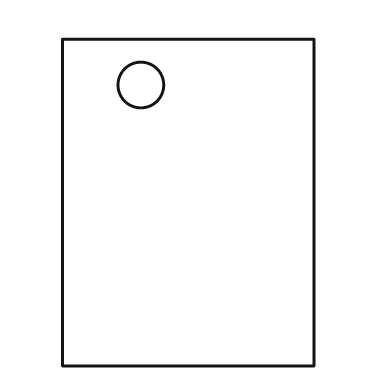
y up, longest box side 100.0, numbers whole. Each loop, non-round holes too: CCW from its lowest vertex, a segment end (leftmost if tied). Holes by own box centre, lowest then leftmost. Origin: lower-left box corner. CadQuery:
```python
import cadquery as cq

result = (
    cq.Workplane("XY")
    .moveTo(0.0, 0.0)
    .lineTo(77.0, 0.0)
    .lineTo(77.0, 100.0)
    .lineTo(0.0, 100.0)
    .close()
    .moveTo(24.0, 86.0)
    .circle(7.0)
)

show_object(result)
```